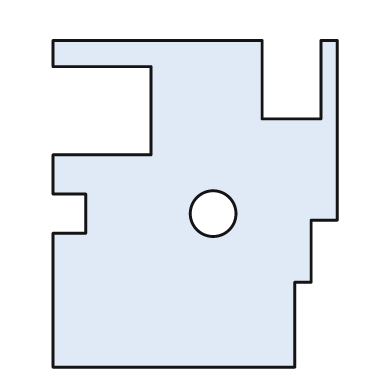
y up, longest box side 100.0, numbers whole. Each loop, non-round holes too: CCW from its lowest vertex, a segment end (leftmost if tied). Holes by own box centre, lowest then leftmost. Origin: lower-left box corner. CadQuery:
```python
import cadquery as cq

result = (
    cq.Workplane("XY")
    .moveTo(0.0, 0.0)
    .lineTo(74.0, 0.0)
    .lineTo(74.0, 26.0)
    .lineTo(79.0, 26.0)
    .lineTo(79.0, 45.0)
    .lineTo(87.0, 45.0)
    .lineTo(87.0, 100.0)
    .lineTo(82.0, 100.0)
    .lineTo(82.0, 76.0)
    .lineTo(64.0, 76.0)
    .lineTo(64.0, 100.0)
    .lineTo(0.0, 100.0)
    .lineTo(0.0, 92.0)
    .lineTo(30.0, 92.0)
    .lineTo(30.0, 65.0)
    .lineTo(0.0, 65.0)
    .lineTo(0.0, 53.0)
    .lineTo(10.0, 53.0)
    .lineTo(10.0, 41.0)
    .lineTo(0.0, 41.0)
    .close()
    .moveTo(49.0, 47.0)
    .circle(7.0)
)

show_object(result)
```